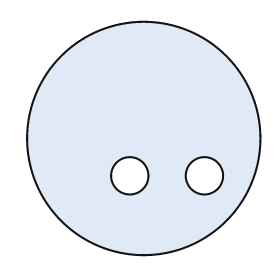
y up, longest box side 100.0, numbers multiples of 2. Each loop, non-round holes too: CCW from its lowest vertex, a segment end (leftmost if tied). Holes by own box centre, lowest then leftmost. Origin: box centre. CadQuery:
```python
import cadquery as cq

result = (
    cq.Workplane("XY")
    .moveTo(0.0, 0.0)
    .circle(50.0)
    .moveTo(-6.0, -16.0)
    .circle(8.0)
    .moveTo(26.0, -16.0)
    .circle(8.0)
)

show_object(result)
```